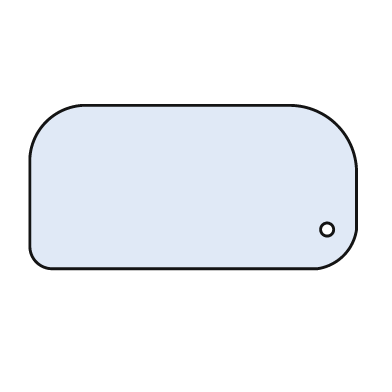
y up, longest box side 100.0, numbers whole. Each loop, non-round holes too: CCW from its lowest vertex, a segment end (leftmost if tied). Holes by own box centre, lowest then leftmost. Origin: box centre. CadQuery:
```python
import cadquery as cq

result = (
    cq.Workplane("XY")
    .moveTo(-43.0, -25.0)
    .lineTo(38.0, -25.0)
    .threePointArc((46.0, -21.0), (50.0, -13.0))
    .lineTo(50.0, 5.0)
    .threePointArc((44.0, 19.0), (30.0, 25.0))
    .lineTo(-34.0, 25.0)
    .threePointArc((-45.0, 20.0), (-50.0, 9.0))
    .lineTo(-50.0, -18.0)
    .threePointArc((-48.0, -23.0), (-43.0, -25.0))
    .close()
    .moveTo(41.0, -13.0)
    .circle(2.0)
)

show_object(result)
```